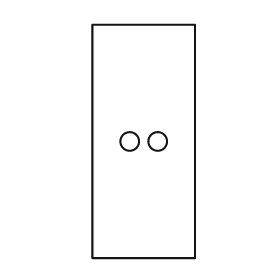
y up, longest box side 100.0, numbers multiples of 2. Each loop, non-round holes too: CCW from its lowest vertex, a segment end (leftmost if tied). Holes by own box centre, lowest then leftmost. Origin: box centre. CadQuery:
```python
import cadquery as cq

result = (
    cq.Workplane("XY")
    .moveTo(-22.0, -50.0)
    .lineTo(22.0, -50.0)
    .lineTo(22.0, 50.0)
    .lineTo(-22.0, 50.0)
    .close()
    .moveTo(-6.0, 0.0)
    .circle(4.0)
    .moveTo(6.0, 0.0)
    .circle(4.0)
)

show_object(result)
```